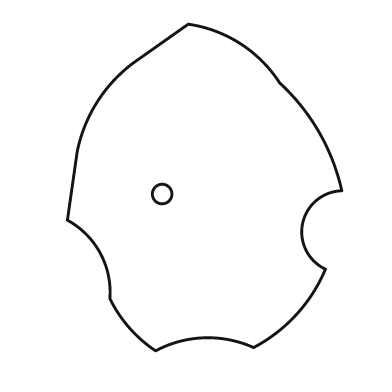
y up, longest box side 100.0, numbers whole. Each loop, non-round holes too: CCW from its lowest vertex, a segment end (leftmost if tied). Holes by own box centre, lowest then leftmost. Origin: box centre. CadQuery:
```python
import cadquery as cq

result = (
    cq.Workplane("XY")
    .moveTo(-15.0, -50.0)
    .threePointArc((0.0, -46.0), (15.0, -49.0))
    .threePointArc((28.0, -39.0), (37.0, -25.0))
    .threePointArc((30.0, -11.0), (42.0, -1.0))
    .threePointArc((35.0, 17.0), (23.0, 32.0))
    .threePointArc((11.0, 44.0), (-5.0, 50.0))
    .lineTo(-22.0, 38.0)
    .threePointArc((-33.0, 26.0), (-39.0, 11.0))
    .lineTo(-42.0, -10.0)
    .threePointArc((-32.0, -20.0), (-29.0, -34.0))
    .threePointArc((-23.0, -43.0), (-15.0, -50.0))
    .close()
    .moveTo(-13.0, -2.0)
    .circle(3.0)
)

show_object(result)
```